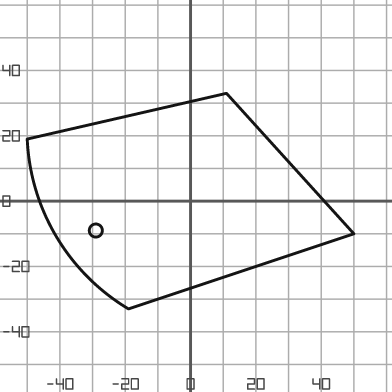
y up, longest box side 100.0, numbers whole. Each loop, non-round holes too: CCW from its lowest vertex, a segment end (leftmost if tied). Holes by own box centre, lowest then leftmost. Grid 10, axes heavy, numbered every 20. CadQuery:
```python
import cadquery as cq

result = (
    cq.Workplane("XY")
    .moveTo(-19.0, -33.0)
    .lineTo(50.0, -10.0)
    .lineTo(11.0, 33.0)
    .lineTo(-50.0, 19.0)
    .threePointArc((-41.0, -11.0), (-19.0, -33.0))
    .close()
    .moveTo(-29.0, -9.0)
    .circle(2.0)
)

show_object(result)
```